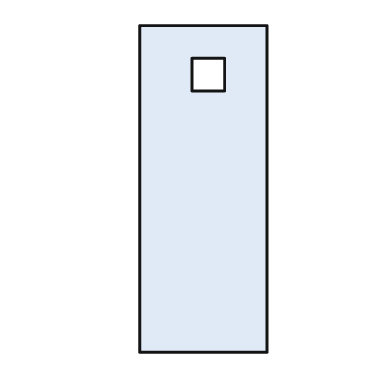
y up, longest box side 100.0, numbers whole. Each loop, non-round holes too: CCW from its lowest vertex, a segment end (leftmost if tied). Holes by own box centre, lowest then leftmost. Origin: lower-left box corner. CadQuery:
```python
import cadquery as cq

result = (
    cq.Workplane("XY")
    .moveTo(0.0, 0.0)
    .lineTo(39.0, 0.0)
    .lineTo(39.0, 100.0)
    .lineTo(0.0, 100.0)
    .close()
    .moveTo(16.0, 80.0)
    .lineTo(26.0, 80.0)
    .lineTo(26.0, 90.0)
    .lineTo(16.0, 90.0)
    .close()
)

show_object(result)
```